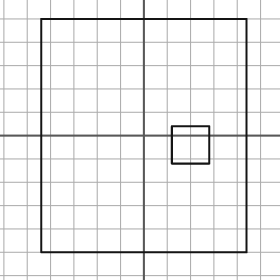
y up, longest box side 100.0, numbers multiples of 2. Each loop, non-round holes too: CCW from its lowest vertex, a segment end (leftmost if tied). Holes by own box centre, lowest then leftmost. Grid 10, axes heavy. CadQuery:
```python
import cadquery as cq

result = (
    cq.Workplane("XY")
    .moveTo(-44.0, -50.0)
    .lineTo(44.0, -50.0)
    .lineTo(44.0, 50.0)
    .lineTo(-44.0, 50.0)
    .close()
    .moveTo(12.0, -12.0)
    .lineTo(28.0, -12.0)
    .lineTo(28.0, 4.0)
    .lineTo(12.0, 4.0)
    .close()
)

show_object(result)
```